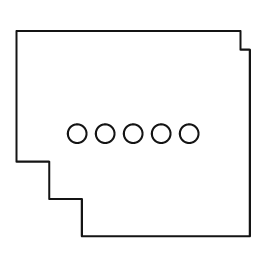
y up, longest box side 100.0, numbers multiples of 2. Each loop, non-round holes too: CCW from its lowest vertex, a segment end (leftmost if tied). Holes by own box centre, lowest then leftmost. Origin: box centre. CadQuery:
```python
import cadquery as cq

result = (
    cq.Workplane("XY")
    .moveTo(-22.0, -44.0)
    .lineTo(50.0, -44.0)
    .lineTo(50.0, 36.0)
    .lineTo(46.0, 36.0)
    .lineTo(46.0, 44.0)
    .lineTo(-50.0, 44.0)
    .lineTo(-50.0, -12.0)
    .lineTo(-36.0, -12.0)
    .lineTo(-36.0, -28.0)
    .lineTo(-22.0, -28.0)
    .close()
    .moveTo(-24.0, 0.0)
    .circle(4.0)
    .moveTo(-12.0, 0.0)
    .circle(4.0)
    .moveTo(0.0, 0.0)
    .circle(4.0)
    .moveTo(12.0, 0.0)
    .circle(4.0)
    .moveTo(24.0, 0.0)
    .circle(4.0)
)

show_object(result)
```